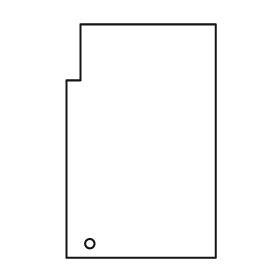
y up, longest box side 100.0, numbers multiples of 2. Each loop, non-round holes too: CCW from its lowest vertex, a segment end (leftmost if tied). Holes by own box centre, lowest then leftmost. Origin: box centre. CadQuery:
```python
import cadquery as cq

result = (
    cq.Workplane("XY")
    .moveTo(-32.0, -50.0)
    .lineTo(32.0, -50.0)
    .lineTo(32.0, 50.0)
    .lineTo(-26.0, 50.0)
    .lineTo(-26.0, 26.0)
    .lineTo(-32.0, 26.0)
    .close()
    .moveTo(-22.0, -44.0)
    .circle(2.0)
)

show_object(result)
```